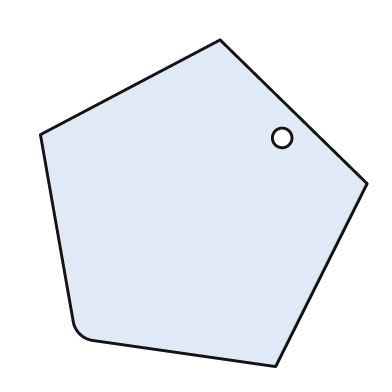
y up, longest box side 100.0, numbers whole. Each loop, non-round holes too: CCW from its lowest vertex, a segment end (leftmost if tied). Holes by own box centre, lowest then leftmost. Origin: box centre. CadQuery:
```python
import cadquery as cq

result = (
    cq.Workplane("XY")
    .moveTo(22.0, -50.0)
    .lineTo(50.0, 6.0)
    .lineTo(5.0, 50.0)
    .lineTo(-50.0, 21.0)
    .lineTo(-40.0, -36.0)
    .threePointArc((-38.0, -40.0), (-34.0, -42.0))
    .close()
    .moveTo(24.0, 20.0)
    .circle(3.0)
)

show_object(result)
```